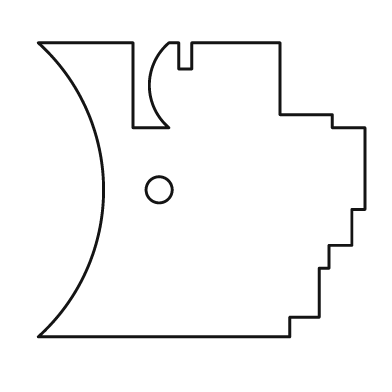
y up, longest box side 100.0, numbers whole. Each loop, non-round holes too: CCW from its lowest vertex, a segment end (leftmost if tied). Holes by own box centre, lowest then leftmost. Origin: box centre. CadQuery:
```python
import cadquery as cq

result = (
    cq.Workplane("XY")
    .moveTo(-50.0, -45.0)
    .lineTo(27.0, -45.0)
    .lineTo(27.0, -39.0)
    .lineTo(36.0, -39.0)
    .lineTo(36.0, -24.0)
    .lineTo(39.0, -24.0)
    .lineTo(39.0, -17.0)
    .lineTo(46.0, -17.0)
    .lineTo(46.0, -6.0)
    .lineTo(50.0, -6.0)
    .lineTo(50.0, 19.0)
    .lineTo(40.0, 19.0)
    .lineTo(40.0, 23.0)
    .lineTo(24.0, 23.0)
    .lineTo(24.0, 45.0)
    .lineTo(-3.0, 45.0)
    .lineTo(-3.0, 37.0)
    .lineTo(-7.0, 37.0)
    .lineTo(-7.0, 45.0)
    .lineTo(-10.0, 45.0)
    .threePointArc((-16.0, 32.0), (-10.0, 19.0))
    .lineTo(-21.0, 19.0)
    .lineTo(-21.0, 45.0)
    .lineTo(-50.0, 45.0)
    .threePointArc((-30.0, 0.0), (-50.0, -45.0))
    .close()
    .moveTo(-13.0, 0.0)
    .circle(4.0)
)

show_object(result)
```